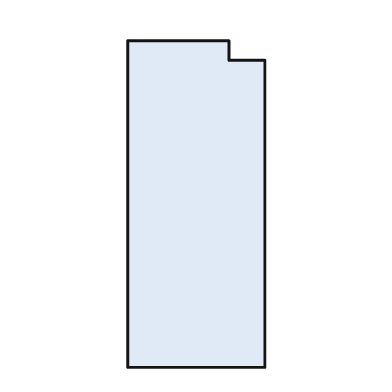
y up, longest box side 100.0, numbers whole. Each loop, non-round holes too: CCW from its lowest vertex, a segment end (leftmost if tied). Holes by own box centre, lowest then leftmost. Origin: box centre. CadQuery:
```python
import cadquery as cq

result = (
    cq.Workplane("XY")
    .moveTo(-21.0, -50.0)
    .lineTo(21.0, -50.0)
    .lineTo(21.0, 44.0)
    .lineTo(10.0, 44.0)
    .lineTo(10.0, 50.0)
    .lineTo(-21.0, 50.0)
    .close()
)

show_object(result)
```